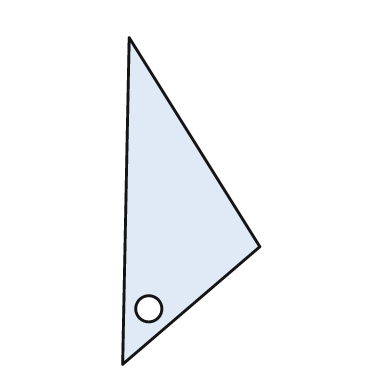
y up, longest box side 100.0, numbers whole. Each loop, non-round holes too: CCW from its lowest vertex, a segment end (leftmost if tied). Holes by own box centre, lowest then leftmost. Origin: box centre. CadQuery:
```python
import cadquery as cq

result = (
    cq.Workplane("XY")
    .moveTo(-21.0, -50.0)
    .lineTo(21.0, -14.0)
    .lineTo(-19.0, 50.0)
    .close()
    .moveTo(-13.0, -33.0)
    .circle(4.0)
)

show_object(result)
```